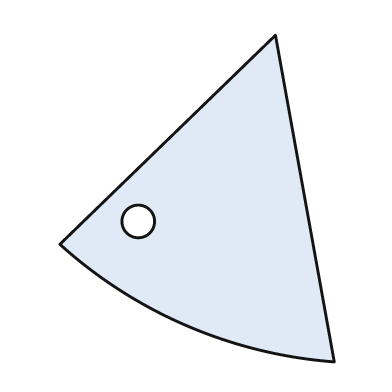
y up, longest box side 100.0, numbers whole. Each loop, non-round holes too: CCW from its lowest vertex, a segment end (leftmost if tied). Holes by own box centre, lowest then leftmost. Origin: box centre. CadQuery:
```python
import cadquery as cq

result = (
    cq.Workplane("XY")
    .moveTo(42.0, -50.0)
    .lineTo(24.0, 50.0)
    .lineTo(-42.0, -14.0)
    .threePointArc((-3.0, -39.0), (42.0, -50.0))
    .close()
    .moveTo(-18.0, -7.0)
    .circle(5.0)
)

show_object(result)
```